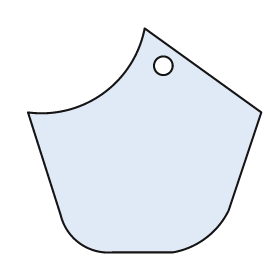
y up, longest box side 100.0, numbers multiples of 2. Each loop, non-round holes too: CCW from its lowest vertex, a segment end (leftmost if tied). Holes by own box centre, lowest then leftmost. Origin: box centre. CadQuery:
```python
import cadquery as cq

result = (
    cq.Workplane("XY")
    .moveTo(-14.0, -48.0)
    .lineTo(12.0, -48.0)
    .threePointArc((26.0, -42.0), (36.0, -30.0))
    .lineTo(50.0, 12.0)
    .lineTo(0.0, 48.0)
    .threePointArc((-18.0, 20.0), (-50.0, 12.0))
    .lineTo(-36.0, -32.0)
    .threePointArc((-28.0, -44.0), (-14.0, -48.0))
    .close()
    .moveTo(8.0, 32.0)
    .circle(4.0)
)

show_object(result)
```